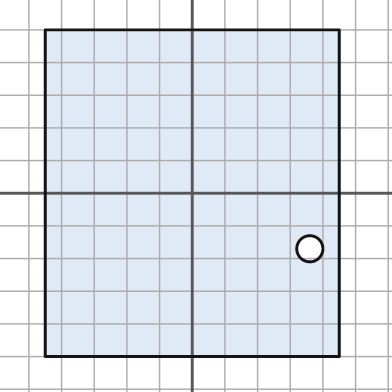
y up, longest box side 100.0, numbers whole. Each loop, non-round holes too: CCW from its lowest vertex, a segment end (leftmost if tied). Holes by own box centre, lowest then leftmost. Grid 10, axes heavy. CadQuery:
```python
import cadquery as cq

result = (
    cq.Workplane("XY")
    .moveTo(-45.0, -50.0)
    .lineTo(45.0, -50.0)
    .lineTo(45.0, 50.0)
    .lineTo(-45.0, 50.0)
    .close()
    .moveTo(36.0, -17.0)
    .circle(4.0)
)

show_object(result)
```